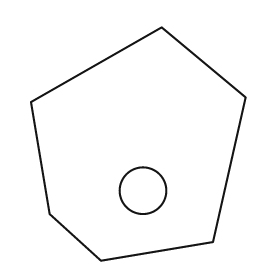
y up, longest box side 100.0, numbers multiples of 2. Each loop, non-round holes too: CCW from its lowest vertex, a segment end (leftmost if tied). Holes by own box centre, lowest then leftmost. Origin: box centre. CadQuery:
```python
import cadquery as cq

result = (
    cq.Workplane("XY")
    .moveTo(-16.0, -50.0)
    .lineTo(32.0, -42.0)
    .lineTo(46.0, 20.0)
    .lineTo(10.0, 50.0)
    .lineTo(-46.0, 18.0)
    .lineTo(-38.0, -30.0)
    .close()
    .moveTo(2.0, -20.0)
    .circle(10.0)
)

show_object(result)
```